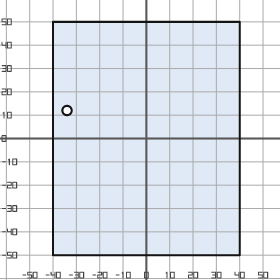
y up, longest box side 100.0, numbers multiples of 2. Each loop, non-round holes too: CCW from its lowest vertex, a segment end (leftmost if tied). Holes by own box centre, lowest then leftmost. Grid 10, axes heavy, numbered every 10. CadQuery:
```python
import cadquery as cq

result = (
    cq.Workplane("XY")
    .moveTo(-40.0, -50.0)
    .lineTo(40.0, -50.0)
    .lineTo(40.0, 50.0)
    .lineTo(-40.0, 50.0)
    .close()
    .moveTo(-34.0, 12.0)
    .circle(2.0)
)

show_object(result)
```